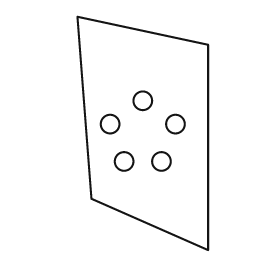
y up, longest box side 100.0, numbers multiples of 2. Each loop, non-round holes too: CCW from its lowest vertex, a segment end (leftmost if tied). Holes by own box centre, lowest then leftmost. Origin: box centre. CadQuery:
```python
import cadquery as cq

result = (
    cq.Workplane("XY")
    .moveTo(28.0, -50.0)
    .lineTo(28.0, 38.0)
    .lineTo(-28.0, 50.0)
    .lineTo(-22.0, -28.0)
    .close()
    .moveTo(-8.0, -12.0)
    .circle(4.0)
    .moveTo(8.0, -12.0)
    .circle(4.0)
    .moveTo(-14.0, 4.0)
    .circle(4.0)
    .moveTo(14.0, 4.0)
    .circle(4.0)
    .moveTo(0.0, 14.0)
    .circle(4.0)
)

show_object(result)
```